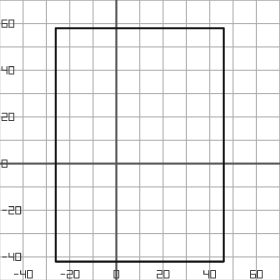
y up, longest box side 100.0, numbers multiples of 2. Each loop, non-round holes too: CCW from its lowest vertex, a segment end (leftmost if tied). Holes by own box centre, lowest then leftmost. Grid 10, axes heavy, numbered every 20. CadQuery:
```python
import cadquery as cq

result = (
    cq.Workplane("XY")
    .moveTo(-26.0, -42.0)
    .lineTo(46.0, -42.0)
    .lineTo(46.0, 58.0)
    .lineTo(-26.0, 58.0)
    .close()
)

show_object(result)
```